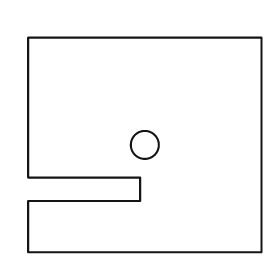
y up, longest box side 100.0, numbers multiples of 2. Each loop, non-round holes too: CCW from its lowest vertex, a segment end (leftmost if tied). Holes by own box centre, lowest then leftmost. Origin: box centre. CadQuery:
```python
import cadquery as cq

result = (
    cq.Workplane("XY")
    .moveTo(-50.0, -46.0)
    .lineTo(50.0, -46.0)
    .lineTo(50.0, 46.0)
    .lineTo(-50.0, 46.0)
    .lineTo(-50.0, -14.0)
    .lineTo(-2.0, -14.0)
    .lineTo(-2.0, -24.0)
    .lineTo(-50.0, -24.0)
    .close()
    .moveTo(0.0, 0.0)
    .circle(6.0)
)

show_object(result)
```